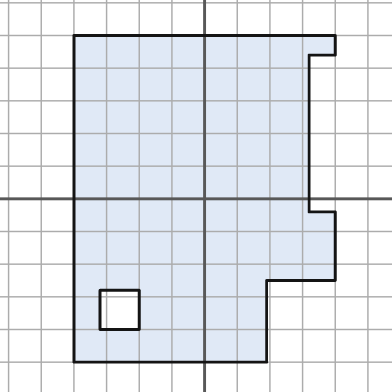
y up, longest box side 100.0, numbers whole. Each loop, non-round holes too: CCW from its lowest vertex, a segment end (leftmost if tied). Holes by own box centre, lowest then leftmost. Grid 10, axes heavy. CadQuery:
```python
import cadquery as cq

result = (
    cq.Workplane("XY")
    .moveTo(-40.0, -50.0)
    .lineTo(19.0, -50.0)
    .lineTo(19.0, -25.0)
    .lineTo(40.0, -25.0)
    .lineTo(40.0, -4.0)
    .lineTo(32.0, -4.0)
    .lineTo(32.0, 44.0)
    .lineTo(40.0, 44.0)
    .lineTo(40.0, 50.0)
    .lineTo(-40.0, 50.0)
    .close()
    .moveTo(-32.0, -40.0)
    .lineTo(-20.0, -40.0)
    .lineTo(-20.0, -28.0)
    .lineTo(-32.0, -28.0)
    .close()
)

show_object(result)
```